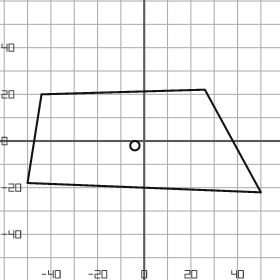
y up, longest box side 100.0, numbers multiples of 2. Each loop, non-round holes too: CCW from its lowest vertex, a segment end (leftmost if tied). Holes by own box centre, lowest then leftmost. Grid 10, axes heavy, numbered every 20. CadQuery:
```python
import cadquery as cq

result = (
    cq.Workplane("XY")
    .moveTo(50.0, -22.0)
    .lineTo(26.0, 22.0)
    .lineTo(-44.0, 20.0)
    .lineTo(-50.0, -18.0)
    .close()
    .moveTo(-4.0, -2.0)
    .circle(2.0)
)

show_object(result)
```